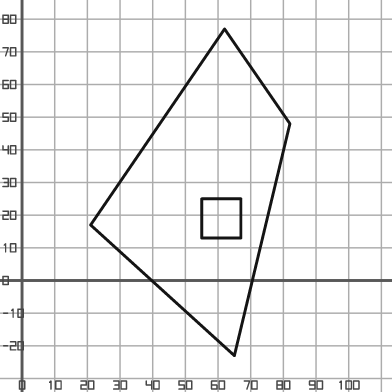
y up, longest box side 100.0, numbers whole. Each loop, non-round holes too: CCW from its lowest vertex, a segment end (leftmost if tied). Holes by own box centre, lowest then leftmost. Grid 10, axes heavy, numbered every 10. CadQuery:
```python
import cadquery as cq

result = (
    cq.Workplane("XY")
    .moveTo(65.0, -23.0)
    .lineTo(82.0, 48.0)
    .lineTo(62.0, 77.0)
    .lineTo(21.0, 17.0)
    .close()
    .moveTo(55.0, 13.0)
    .lineTo(67.0, 13.0)
    .lineTo(67.0, 25.0)
    .lineTo(55.0, 25.0)
    .close()
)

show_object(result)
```